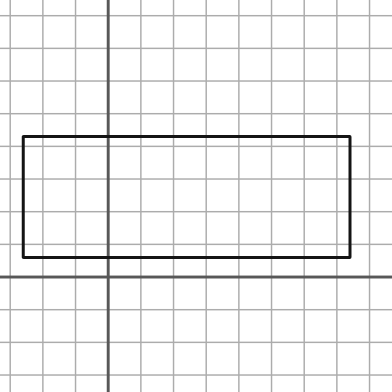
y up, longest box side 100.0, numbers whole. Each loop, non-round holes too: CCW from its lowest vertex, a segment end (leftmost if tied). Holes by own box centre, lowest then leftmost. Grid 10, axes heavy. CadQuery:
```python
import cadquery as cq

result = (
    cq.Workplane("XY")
    .moveTo(-26.0, 6.0)
    .lineTo(74.0, 6.0)
    .lineTo(74.0, 43.0)
    .lineTo(-26.0, 43.0)
    .close()
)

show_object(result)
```